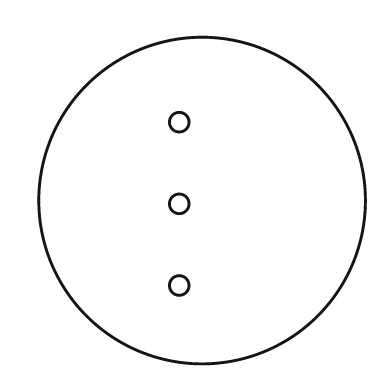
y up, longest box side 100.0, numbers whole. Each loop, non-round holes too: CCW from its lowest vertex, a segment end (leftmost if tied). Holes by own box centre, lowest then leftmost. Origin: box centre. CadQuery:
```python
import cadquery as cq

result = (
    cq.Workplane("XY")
    .moveTo(0.0, 0.0)
    .circle(50.0)
    .moveTo(-7.0, -26.0)
    .circle(3.0)
    .moveTo(-7.0, -1.0)
    .circle(3.0)
    .moveTo(-7.0, 24.0)
    .circle(3.0)
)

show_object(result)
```